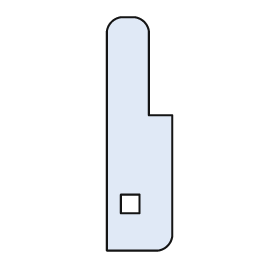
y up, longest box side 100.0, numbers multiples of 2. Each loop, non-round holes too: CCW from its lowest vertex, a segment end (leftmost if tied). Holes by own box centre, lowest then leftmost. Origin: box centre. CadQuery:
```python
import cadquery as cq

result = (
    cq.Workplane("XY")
    .moveTo(-14.0, -50.0)
    .lineTo(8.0, -50.0)
    .threePointArc((12.0, -48.0), (14.0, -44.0))
    .lineTo(14.0, 8.0)
    .lineTo(4.0, 8.0)
    .lineTo(4.0, 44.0)
    .threePointArc((2.0, 48.0), (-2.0, 50.0))
    .lineTo(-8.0, 50.0)
    .threePointArc((-12.0, 48.0), (-14.0, 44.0))
    .close()
    .moveTo(-8.0, -34.0)
    .lineTo(0.0, -34.0)
    .lineTo(0.0, -26.0)
    .lineTo(-8.0, -26.0)
    .close()
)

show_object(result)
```